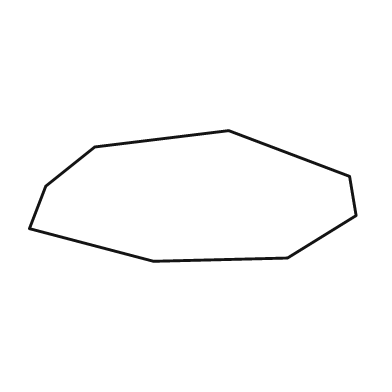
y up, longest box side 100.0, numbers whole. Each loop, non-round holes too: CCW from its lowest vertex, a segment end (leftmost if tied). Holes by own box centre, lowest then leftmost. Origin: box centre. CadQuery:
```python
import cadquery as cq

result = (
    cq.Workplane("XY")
    .moveTo(-12.0, -20.0)
    .lineTo(29.0, -19.0)
    .lineTo(50.0, -6.0)
    .lineTo(48.0, 6.0)
    .lineTo(11.0, 20.0)
    .lineTo(-30.0, 15.0)
    .lineTo(-45.0, 3.0)
    .lineTo(-50.0, -10.0)
    .close()
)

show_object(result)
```